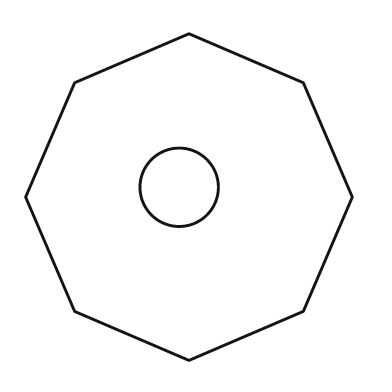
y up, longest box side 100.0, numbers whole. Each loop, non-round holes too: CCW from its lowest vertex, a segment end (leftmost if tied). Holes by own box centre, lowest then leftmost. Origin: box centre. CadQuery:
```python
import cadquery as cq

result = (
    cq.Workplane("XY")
    .moveTo(0.0, -50.0)
    .lineTo(35.0, -35.0)
    .lineTo(50.0, 0.0)
    .lineTo(35.0, 35.0)
    .lineTo(0.0, 50.0)
    .lineTo(-35.0, 35.0)
    .lineTo(-50.0, 0.0)
    .lineTo(-35.0, -35.0)
    .close()
    .moveTo(-3.0, 3.0)
    .circle(12.0)
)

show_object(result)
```